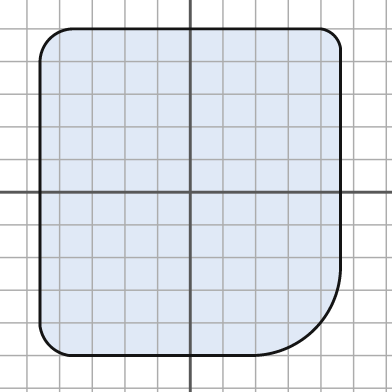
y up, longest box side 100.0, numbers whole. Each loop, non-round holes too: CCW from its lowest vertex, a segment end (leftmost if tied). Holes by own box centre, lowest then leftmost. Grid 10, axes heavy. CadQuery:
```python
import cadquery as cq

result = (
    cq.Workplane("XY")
    .moveTo(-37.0, -50.0)
    .lineTo(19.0, -50.0)
    .threePointArc((38.0, -42.0), (46.0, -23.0))
    .lineTo(46.0, 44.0)
    .threePointArc((44.0, 48.0), (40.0, 50.0))
    .lineTo(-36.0, 50.0)
    .threePointArc((-43.0, 47.0), (-46.0, 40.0))
    .lineTo(-46.0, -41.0)
    .threePointArc((-43.0, -47.0), (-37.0, -50.0))
    .close()
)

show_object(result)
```